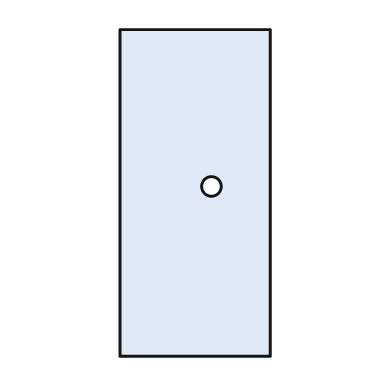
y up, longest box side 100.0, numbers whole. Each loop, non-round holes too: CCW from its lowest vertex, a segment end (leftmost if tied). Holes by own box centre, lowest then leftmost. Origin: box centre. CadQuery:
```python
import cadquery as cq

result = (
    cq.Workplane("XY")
    .moveTo(-23.0, -50.0)
    .lineTo(23.0, -50.0)
    .lineTo(23.0, 50.0)
    .lineTo(-23.0, 50.0)
    .close()
    .moveTo(5.0, 2.0)
    .circle(3.0)
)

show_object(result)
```